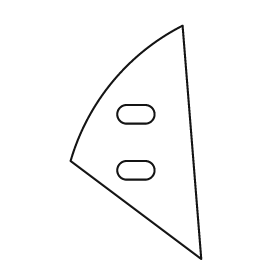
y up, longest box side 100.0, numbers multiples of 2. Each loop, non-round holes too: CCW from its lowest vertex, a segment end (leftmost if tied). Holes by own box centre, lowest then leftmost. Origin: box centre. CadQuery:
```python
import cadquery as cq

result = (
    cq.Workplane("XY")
    .moveTo(28.0, -50.0)
    .lineTo(20.0, 50.0)
    .threePointArc((-10.0, 26.0), (-28.0, -8.0))
    .close()
    .moveTo(-4.0, -16.0)
    .lineTo(4.0, -16.0)
    .threePointArc((8.0, -12.0), (4.0, -8.0))
    .lineTo(-4.0, -8.0)
    .threePointArc((-8.0, -12.0), (-4.0, -16.0))
    .close()
    .moveTo(-4.0, 8.0)
    .lineTo(4.0, 8.0)
    .threePointArc((8.0, 12.0), (4.0, 16.0))
    .lineTo(-4.0, 16.0)
    .threePointArc((-8.0, 12.0), (-4.0, 8.0))
    .close()
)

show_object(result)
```